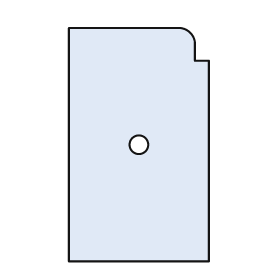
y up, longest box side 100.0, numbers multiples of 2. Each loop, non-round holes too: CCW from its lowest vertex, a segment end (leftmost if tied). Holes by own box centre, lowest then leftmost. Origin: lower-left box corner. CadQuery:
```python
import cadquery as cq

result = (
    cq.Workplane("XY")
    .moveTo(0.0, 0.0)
    .lineTo(60.0, 0.0)
    .lineTo(60.0, 86.0)
    .lineTo(54.0, 86.0)
    .lineTo(54.0, 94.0)
    .threePointArc((52.0, 98.0), (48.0, 100.0))
    .lineTo(0.0, 100.0)
    .close()
    .moveTo(30.0, 50.0)
    .circle(4.0)
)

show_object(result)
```